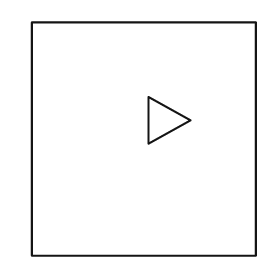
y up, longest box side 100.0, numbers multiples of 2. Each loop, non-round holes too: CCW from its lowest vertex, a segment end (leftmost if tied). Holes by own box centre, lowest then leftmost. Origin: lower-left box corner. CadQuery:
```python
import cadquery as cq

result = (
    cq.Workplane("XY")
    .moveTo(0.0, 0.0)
    .lineTo(96.0, 0.0)
    .lineTo(96.0, 100.0)
    .lineTo(0.0, 100.0)
    .close()
    .moveTo(50.0, 48.0)
    .lineTo(68.0, 58.0)
    .lineTo(50.0, 68.0)
    .close()
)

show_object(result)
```